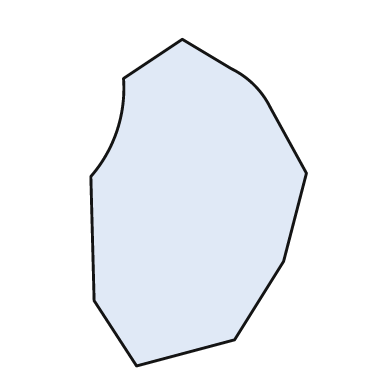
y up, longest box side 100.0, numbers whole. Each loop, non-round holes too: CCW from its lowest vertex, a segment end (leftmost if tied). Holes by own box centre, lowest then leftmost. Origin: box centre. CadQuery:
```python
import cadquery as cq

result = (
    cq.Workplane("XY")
    .moveTo(-19.0, -50.0)
    .lineTo(11.0, -42.0)
    .lineTo(26.0, -18.0)
    .lineTo(33.0, 9.0)
    .lineTo(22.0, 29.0)
    .threePointArc((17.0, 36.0), (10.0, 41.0))
    .lineTo(-5.0, 50.0)
    .lineTo(-23.0, 38.0)
    .threePointArc((-25.0, 22.0), (-33.0, 8.0))
    .lineTo(-32.0, -30.0)
    .close()
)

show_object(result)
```